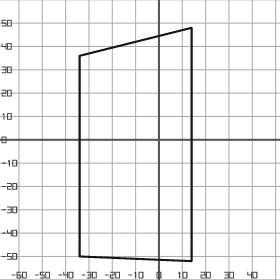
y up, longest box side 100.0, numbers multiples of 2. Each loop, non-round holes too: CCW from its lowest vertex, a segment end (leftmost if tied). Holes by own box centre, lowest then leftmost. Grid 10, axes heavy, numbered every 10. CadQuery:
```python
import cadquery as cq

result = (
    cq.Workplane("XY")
    .moveTo(14.0, -52.0)
    .lineTo(14.0, 48.0)
    .lineTo(-34.0, 36.0)
    .lineTo(-34.0, -50.0)
    .close()
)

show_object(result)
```